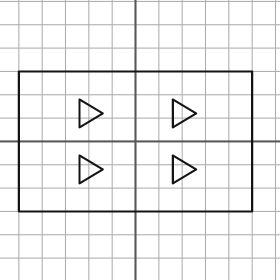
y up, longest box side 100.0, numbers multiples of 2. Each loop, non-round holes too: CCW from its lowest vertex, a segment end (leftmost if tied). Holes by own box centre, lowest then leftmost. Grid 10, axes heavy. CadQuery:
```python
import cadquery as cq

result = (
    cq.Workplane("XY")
    .moveTo(-50.0, -30.0)
    .lineTo(50.0, -30.0)
    .lineTo(50.0, 30.0)
    .lineTo(-50.0, 30.0)
    .close()
    .moveTo(-24.0, -18.0)
    .lineTo(-14.0, -12.0)
    .lineTo(-24.0, -6.0)
    .close()
    .moveTo(16.0, -18.0)
    .lineTo(26.0, -12.0)
    .lineTo(16.0, -6.0)
    .close()
    .moveTo(-24.0, 6.0)
    .lineTo(-14.0, 12.0)
    .lineTo(-24.0, 18.0)
    .close()
    .moveTo(16.0, 6.0)
    .lineTo(26.0, 12.0)
    .lineTo(16.0, 18.0)
    .close()
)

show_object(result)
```